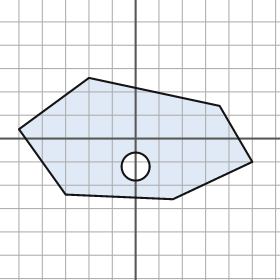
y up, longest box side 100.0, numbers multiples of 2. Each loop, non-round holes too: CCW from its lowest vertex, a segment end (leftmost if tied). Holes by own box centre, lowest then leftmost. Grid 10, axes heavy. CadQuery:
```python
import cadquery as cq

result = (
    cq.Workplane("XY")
    .moveTo(16.0, -26.0)
    .lineTo(50.0, -10.0)
    .lineTo(36.0, 14.0)
    .lineTo(-20.0, 26.0)
    .lineTo(-50.0, 4.0)
    .lineTo(-30.0, -24.0)
    .close()
    .moveTo(0.0, -12.0)
    .circle(6.0)
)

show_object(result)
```